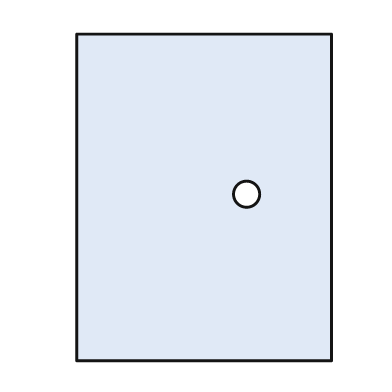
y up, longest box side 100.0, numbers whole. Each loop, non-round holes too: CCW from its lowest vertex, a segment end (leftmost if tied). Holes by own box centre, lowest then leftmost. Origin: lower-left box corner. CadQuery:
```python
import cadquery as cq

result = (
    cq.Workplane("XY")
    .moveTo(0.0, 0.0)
    .lineTo(78.0, 0.0)
    .lineTo(78.0, 100.0)
    .lineTo(0.0, 100.0)
    .close()
    .moveTo(52.0, 51.0)
    .circle(4.0)
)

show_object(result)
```